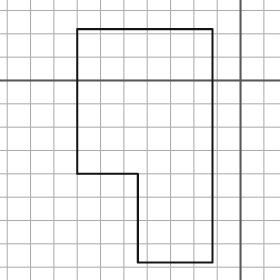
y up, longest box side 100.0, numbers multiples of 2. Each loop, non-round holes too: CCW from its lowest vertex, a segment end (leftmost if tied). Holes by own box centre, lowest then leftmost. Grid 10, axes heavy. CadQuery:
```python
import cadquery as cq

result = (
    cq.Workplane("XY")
    .moveTo(-44.0, -78.0)
    .lineTo(-12.0, -78.0)
    .lineTo(-12.0, 22.0)
    .lineTo(-70.0, 22.0)
    .lineTo(-70.0, -40.0)
    .lineTo(-44.0, -40.0)
    .close()
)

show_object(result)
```